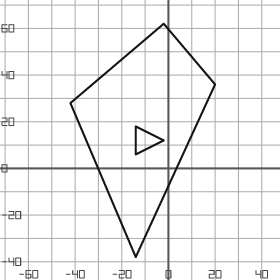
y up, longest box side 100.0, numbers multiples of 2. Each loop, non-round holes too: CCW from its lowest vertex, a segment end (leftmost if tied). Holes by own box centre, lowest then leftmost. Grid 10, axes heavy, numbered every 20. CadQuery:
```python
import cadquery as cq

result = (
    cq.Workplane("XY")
    .moveTo(-14.0, -38.0)
    .lineTo(20.0, 36.0)
    .lineTo(-2.0, 62.0)
    .lineTo(-42.0, 28.0)
    .close()
    .moveTo(-14.0, 6.0)
    .lineTo(-2.0, 12.0)
    .lineTo(-14.0, 18.0)
    .close()
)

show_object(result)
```